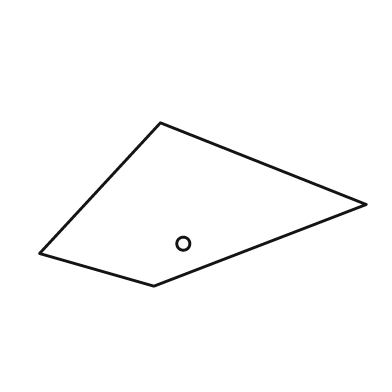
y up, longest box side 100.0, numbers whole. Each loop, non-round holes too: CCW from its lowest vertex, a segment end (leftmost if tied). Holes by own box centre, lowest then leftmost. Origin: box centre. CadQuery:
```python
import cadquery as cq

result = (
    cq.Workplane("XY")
    .moveTo(-15.0, -25.0)
    .lineTo(50.0, 0.0)
    .lineTo(-13.0, 25.0)
    .lineTo(-50.0, -15.0)
    .close()
    .moveTo(-6.0, -12.0)
    .circle(2.0)
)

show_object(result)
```